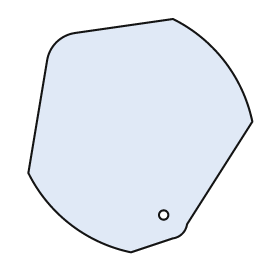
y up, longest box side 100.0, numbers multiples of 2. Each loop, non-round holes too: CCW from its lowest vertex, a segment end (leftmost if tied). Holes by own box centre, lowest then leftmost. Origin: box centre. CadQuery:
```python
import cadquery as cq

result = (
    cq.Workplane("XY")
    .moveTo(-4.0, -50.0)
    .lineTo(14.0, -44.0)
    .threePointArc((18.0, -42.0), (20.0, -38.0))
    .lineTo(48.0, 6.0)
    .threePointArc((36.0, 32.0), (14.0, 50.0))
    .lineTo(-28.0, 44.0)
    .threePointArc((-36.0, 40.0), (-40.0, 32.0))
    .lineTo(-48.0, -16.0)
    .threePointArc((-30.0, -38.0), (-4.0, -50.0))
    .close()
    .moveTo(10.0, -34.0)
    .circle(2.0)
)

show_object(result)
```